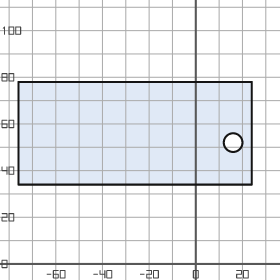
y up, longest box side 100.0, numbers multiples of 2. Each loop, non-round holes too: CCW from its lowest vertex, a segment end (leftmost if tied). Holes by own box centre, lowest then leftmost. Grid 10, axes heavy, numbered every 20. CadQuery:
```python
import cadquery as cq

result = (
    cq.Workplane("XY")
    .moveTo(-76.0, 34.0)
    .lineTo(24.0, 34.0)
    .lineTo(24.0, 78.0)
    .lineTo(-76.0, 78.0)
    .close()
    .moveTo(16.0, 52.0)
    .circle(4.0)
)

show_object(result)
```